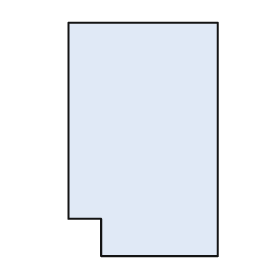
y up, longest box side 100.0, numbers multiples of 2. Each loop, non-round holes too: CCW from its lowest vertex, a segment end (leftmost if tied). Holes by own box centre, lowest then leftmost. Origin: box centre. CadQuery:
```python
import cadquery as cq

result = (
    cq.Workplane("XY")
    .moveTo(-18.0, -50.0)
    .lineTo(32.0, -50.0)
    .lineTo(32.0, 50.0)
    .lineTo(-32.0, 50.0)
    .lineTo(-32.0, -34.0)
    .lineTo(-18.0, -34.0)
    .close()
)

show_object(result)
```